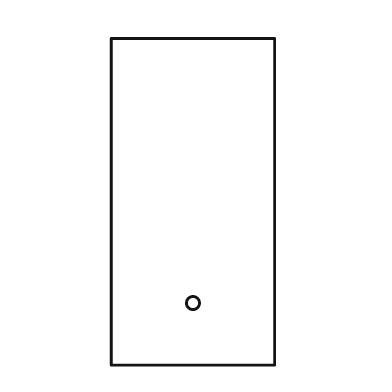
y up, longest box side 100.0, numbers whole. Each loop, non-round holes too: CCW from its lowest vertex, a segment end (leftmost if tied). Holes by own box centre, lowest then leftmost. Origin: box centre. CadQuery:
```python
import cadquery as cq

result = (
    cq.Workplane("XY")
    .moveTo(-25.0, -50.0)
    .lineTo(25.0, -50.0)
    .lineTo(25.0, 50.0)
    .lineTo(-25.0, 50.0)
    .close()
    .moveTo(0.0, -31.0)
    .circle(2.0)
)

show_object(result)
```